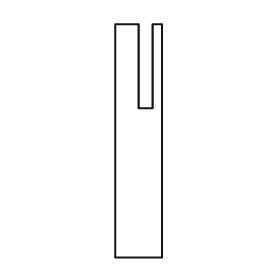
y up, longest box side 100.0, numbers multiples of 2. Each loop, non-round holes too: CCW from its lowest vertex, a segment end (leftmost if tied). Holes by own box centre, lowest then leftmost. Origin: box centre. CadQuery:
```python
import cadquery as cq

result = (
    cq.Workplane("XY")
    .moveTo(-10.0, -50.0)
    .lineTo(10.0, -50.0)
    .lineTo(10.0, 50.0)
    .lineTo(6.0, 50.0)
    .lineTo(6.0, 14.0)
    .lineTo(0.0, 14.0)
    .lineTo(0.0, 50.0)
    .lineTo(-10.0, 50.0)
    .close()
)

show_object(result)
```